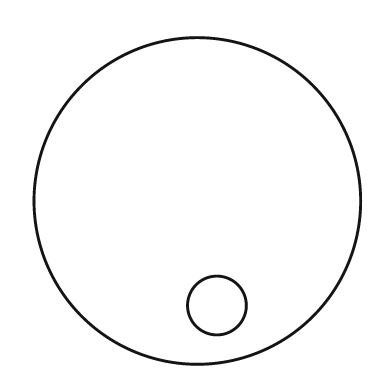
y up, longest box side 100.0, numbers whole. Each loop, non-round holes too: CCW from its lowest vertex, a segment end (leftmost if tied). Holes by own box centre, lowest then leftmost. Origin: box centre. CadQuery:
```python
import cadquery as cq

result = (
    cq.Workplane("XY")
    .moveTo(0.0, 0.0)
    .circle(50.0)
    .moveTo(6.0, -32.0)
    .circle(9.0)
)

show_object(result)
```